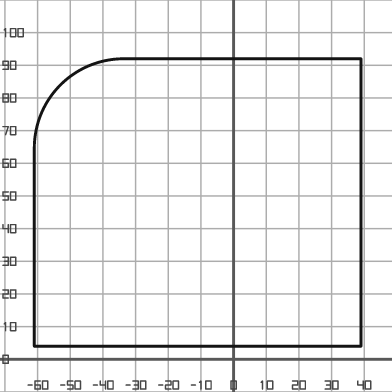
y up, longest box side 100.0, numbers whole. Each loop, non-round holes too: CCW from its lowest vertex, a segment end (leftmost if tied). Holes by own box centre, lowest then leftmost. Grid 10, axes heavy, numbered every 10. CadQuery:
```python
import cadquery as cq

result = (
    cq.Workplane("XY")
    .moveTo(-61.0, 4.0)
    .lineTo(39.0, 4.0)
    .lineTo(39.0, 92.0)
    .lineTo(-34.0, 92.0)
    .threePointArc((-53.0, 84.0), (-61.0, 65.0))
    .close()
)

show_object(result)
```